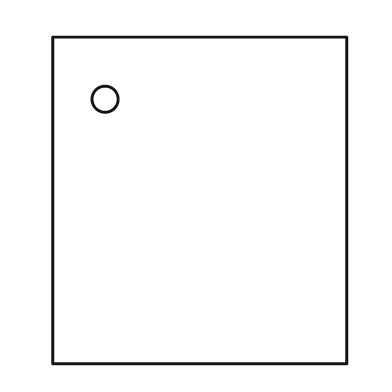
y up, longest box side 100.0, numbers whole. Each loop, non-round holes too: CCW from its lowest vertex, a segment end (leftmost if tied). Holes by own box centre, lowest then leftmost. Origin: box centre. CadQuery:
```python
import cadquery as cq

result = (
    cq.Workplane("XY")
    .moveTo(-45.0, -50.0)
    .lineTo(45.0, -50.0)
    .lineTo(45.0, 50.0)
    .lineTo(-45.0, 50.0)
    .close()
    .moveTo(-29.0, 31.0)
    .circle(4.0)
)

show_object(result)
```